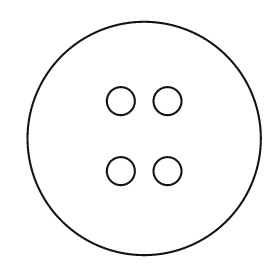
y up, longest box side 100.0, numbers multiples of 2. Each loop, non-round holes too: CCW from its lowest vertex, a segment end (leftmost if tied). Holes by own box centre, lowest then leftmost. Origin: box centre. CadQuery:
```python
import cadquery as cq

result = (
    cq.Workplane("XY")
    .moveTo(0.0, 0.0)
    .circle(50.0)
    .moveTo(-10.0, -14.0)
    .circle(6.0)
    .moveTo(10.0, -14.0)
    .circle(6.0)
    .moveTo(-10.0, 16.0)
    .circle(6.0)
    .moveTo(10.0, 16.0)
    .circle(6.0)
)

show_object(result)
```